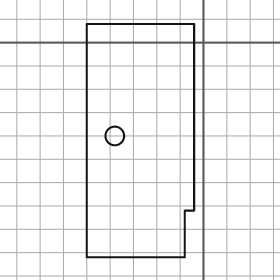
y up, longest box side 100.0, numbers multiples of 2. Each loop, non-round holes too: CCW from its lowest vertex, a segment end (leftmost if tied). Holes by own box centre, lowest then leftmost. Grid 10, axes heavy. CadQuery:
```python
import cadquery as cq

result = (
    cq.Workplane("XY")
    .moveTo(-50.0, -92.0)
    .lineTo(-8.0, -92.0)
    .lineTo(-8.0, -72.0)
    .lineTo(-4.0, -72.0)
    .lineTo(-4.0, 8.0)
    .lineTo(-50.0, 8.0)
    .close()
    .moveTo(-38.0, -40.0)
    .circle(4.0)
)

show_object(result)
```